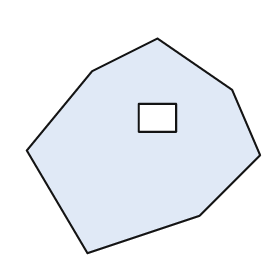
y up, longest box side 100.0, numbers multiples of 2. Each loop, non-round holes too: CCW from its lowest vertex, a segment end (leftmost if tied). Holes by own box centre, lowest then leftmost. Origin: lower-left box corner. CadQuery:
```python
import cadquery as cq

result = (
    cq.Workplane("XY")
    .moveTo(26.0, 0.0)
    .lineTo(74.0, 16.0)
    .lineTo(100.0, 42.0)
    .lineTo(88.0, 70.0)
    .lineTo(56.0, 92.0)
    .lineTo(28.0, 78.0)
    .lineTo(0.0, 44.0)
    .close()
    .moveTo(48.0, 52.0)
    .lineTo(64.0, 52.0)
    .lineTo(64.0, 64.0)
    .lineTo(48.0, 64.0)
    .close()
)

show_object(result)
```